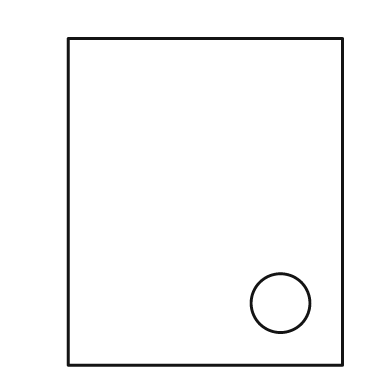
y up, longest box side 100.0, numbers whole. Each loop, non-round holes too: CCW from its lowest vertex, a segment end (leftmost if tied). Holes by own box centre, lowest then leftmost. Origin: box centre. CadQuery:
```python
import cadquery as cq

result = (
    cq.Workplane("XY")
    .moveTo(-42.0, -50.0)
    .lineTo(42.0, -50.0)
    .lineTo(42.0, 50.0)
    .lineTo(-42.0, 50.0)
    .close()
    .moveTo(23.0, -31.0)
    .circle(9.0)
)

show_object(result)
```